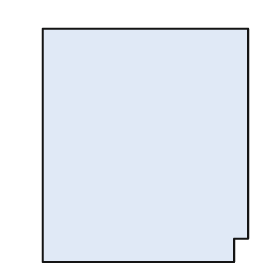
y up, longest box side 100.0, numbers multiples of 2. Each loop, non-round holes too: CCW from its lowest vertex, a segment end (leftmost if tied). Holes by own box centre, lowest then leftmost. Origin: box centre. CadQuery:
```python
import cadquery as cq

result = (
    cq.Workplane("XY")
    .moveTo(-44.0, -50.0)
    .lineTo(38.0, -50.0)
    .lineTo(38.0, -40.0)
    .lineTo(44.0, -40.0)
    .lineTo(44.0, 50.0)
    .lineTo(-44.0, 50.0)
    .close()
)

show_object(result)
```